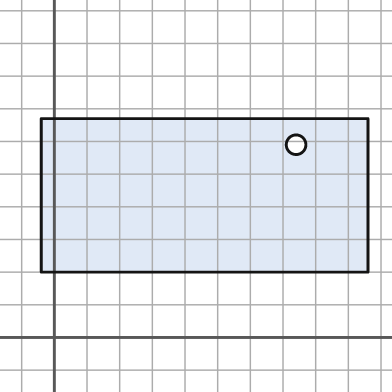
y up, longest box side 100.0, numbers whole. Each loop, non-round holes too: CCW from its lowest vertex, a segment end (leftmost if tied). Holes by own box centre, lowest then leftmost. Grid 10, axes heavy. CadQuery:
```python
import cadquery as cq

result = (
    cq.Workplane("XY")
    .moveTo(-4.0, 20.0)
    .lineTo(96.0, 20.0)
    .lineTo(96.0, 67.0)
    .lineTo(-4.0, 67.0)
    .close()
    .moveTo(74.0, 59.0)
    .circle(3.0)
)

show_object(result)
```